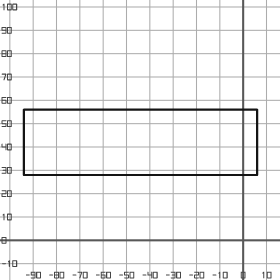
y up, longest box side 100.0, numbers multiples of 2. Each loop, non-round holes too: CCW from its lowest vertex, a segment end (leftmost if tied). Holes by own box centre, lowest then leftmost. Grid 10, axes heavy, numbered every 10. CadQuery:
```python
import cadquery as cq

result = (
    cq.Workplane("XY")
    .moveTo(-94.0, 28.0)
    .lineTo(6.0, 28.0)
    .lineTo(6.0, 56.0)
    .lineTo(-94.0, 56.0)
    .close()
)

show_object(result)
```